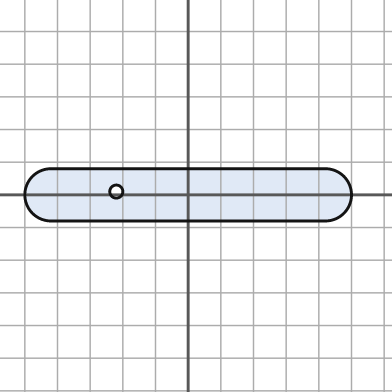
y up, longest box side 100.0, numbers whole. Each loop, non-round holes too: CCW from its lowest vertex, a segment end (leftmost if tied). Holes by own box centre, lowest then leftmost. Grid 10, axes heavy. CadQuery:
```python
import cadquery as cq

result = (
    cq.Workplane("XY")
    .moveTo(-42.0, -8.0)
    .lineTo(42.0, -8.0)
    .threePointArc((50.0, 0.0), (42.0, 8.0))
    .lineTo(-42.0, 8.0)
    .threePointArc((-50.0, 0.0), (-42.0, -8.0))
    .close()
    .moveTo(-22.0, 1.0)
    .circle(2.0)
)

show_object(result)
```